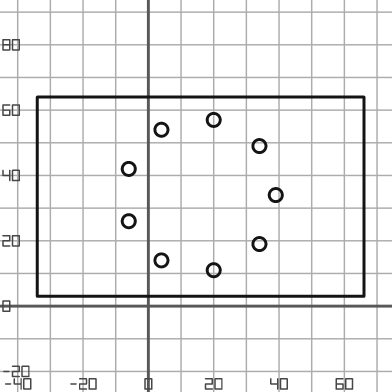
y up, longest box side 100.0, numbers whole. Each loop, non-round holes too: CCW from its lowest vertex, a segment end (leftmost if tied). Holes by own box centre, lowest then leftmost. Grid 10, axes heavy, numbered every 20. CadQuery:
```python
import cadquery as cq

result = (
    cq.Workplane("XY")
    .moveTo(-34.0, 3.0)
    .lineTo(66.0, 3.0)
    .lineTo(66.0, 64.0)
    .lineTo(-34.0, 64.0)
    .close()
    .moveTo(20.0, 11.0)
    .circle(2.0)
    .moveTo(4.0, 14.0)
    .circle(2.0)
    .moveTo(34.0, 19.0)
    .circle(2.0)
    .moveTo(-6.0, 26.0)
    .circle(2.0)
    .moveTo(39.0, 34.0)
    .circle(2.0)
    .moveTo(-6.0, 42.0)
    .circle(2.0)
    .moveTo(34.0, 49.0)
    .circle(2.0)
    .moveTo(4.0, 54.0)
    .circle(2.0)
    .moveTo(20.0, 57.0)
    .circle(2.0)
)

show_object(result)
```